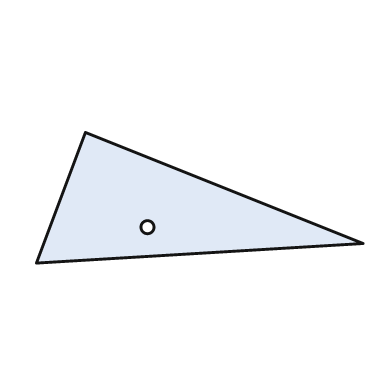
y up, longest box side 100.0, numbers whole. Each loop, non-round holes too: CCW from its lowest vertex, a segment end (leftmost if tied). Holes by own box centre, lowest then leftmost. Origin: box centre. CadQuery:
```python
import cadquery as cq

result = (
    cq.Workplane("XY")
    .moveTo(-50.0, -20.0)
    .lineTo(50.0, -14.0)
    .lineTo(-35.0, 20.0)
    .close()
    .moveTo(-16.0, -9.0)
    .circle(2.0)
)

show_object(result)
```